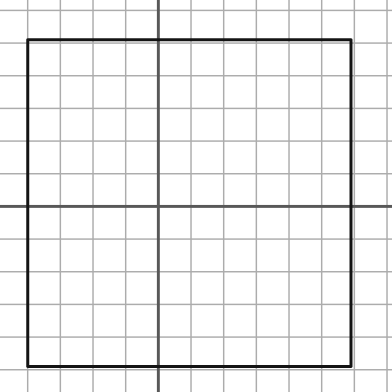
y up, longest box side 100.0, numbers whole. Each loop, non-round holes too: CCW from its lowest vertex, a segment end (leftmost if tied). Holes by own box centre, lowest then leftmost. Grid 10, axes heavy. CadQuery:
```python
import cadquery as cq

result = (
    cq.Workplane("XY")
    .moveTo(-40.0, -49.0)
    .lineTo(59.0, -49.0)
    .lineTo(59.0, 51.0)
    .lineTo(-40.0, 51.0)
    .close()
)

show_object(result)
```